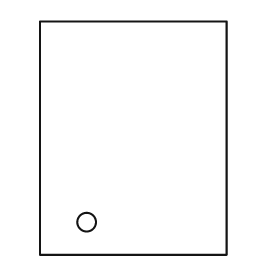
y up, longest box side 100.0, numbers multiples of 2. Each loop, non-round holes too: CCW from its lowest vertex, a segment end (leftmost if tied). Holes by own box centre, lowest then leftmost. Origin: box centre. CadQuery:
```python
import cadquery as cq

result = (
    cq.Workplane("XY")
    .moveTo(-40.0, -50.0)
    .lineTo(40.0, -50.0)
    .lineTo(40.0, 50.0)
    .lineTo(-40.0, 50.0)
    .close()
    .moveTo(-20.0, -36.0)
    .circle(4.0)
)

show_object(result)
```